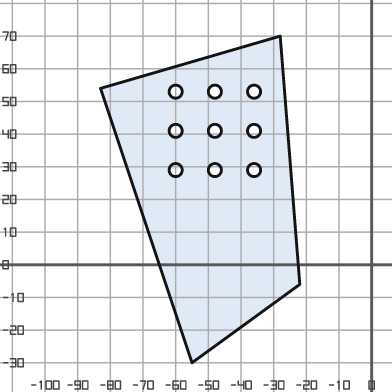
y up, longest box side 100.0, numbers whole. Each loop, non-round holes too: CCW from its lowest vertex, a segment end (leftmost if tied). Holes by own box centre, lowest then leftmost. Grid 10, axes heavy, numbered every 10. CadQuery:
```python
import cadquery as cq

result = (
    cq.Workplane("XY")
    .moveTo(-55.0, -30.0)
    .lineTo(-22.0, -6.0)
    .lineTo(-28.0, 70.0)
    .lineTo(-83.0, 54.0)
    .close()
    .moveTo(-60.0, 29.0)
    .circle(2.0)
    .moveTo(-48.0, 29.0)
    .circle(2.0)
    .moveTo(-36.0, 29.0)
    .circle(2.0)
    .moveTo(-60.0, 41.0)
    .circle(2.0)
    .moveTo(-48.0, 41.0)
    .circle(2.0)
    .moveTo(-36.0, 41.0)
    .circle(2.0)
    .moveTo(-60.0, 53.0)
    .circle(2.0)
    .moveTo(-48.0, 53.0)
    .circle(2.0)
    .moveTo(-36.0, 53.0)
    .circle(2.0)
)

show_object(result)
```